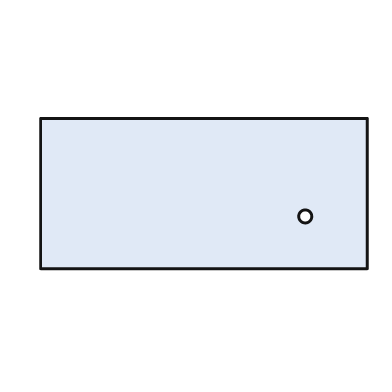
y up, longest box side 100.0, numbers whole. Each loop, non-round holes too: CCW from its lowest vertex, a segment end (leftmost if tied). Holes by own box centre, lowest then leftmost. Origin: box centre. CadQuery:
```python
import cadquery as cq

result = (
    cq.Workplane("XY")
    .moveTo(-50.0, -23.0)
    .lineTo(50.0, -23.0)
    .lineTo(50.0, 23.0)
    .lineTo(-50.0, 23.0)
    .close()
    .moveTo(31.0, -7.0)
    .circle(2.0)
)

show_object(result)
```